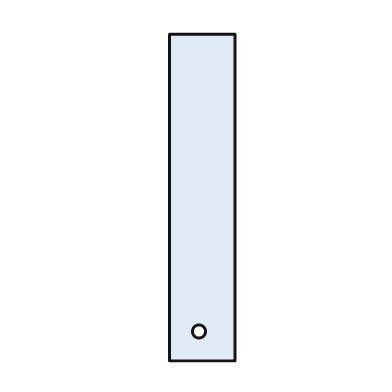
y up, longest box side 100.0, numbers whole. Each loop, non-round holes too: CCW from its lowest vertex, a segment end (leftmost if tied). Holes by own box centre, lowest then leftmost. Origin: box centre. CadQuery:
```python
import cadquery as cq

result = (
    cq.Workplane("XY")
    .moveTo(-10.0, -50.0)
    .lineTo(10.0, -50.0)
    .lineTo(10.0, 50.0)
    .lineTo(-10.0, 50.0)
    .close()
    .moveTo(-1.0, -41.0)
    .circle(2.0)
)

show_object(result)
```